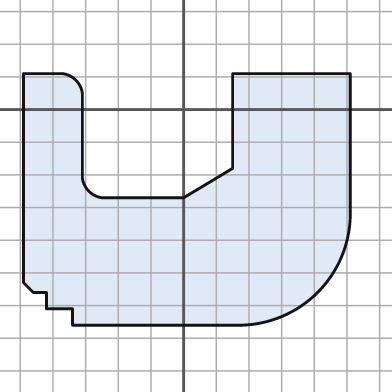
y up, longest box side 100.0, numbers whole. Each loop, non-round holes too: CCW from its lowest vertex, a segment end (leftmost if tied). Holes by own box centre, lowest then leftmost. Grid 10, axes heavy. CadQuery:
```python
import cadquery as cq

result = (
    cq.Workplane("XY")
    .moveTo(-34.0, -66.0)
    .lineTo(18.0, -66.0)
    .threePointArc((41.0, -56.0), (51.0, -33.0))
    .lineTo(51.0, 11.0)
    .lineTo(15.0, 11.0)
    .lineTo(15.0, -18.0)
    .lineTo(0.0, -27.0)
    .lineTo(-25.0, -27.0)
    .threePointArc((-29.0, -25.0), (-31.0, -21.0))
    .lineTo(-31.0, 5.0)
    .threePointArc((-33.0, 9.0), (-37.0, 11.0))
    .lineTo(-49.0, 11.0)
    .lineTo(-49.0, -53.0)
    .lineTo(-46.0, -56.0)
    .lineTo(-42.0, -56.0)
    .lineTo(-42.0, -61.0)
    .lineTo(-34.0, -61.0)
    .close()
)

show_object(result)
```